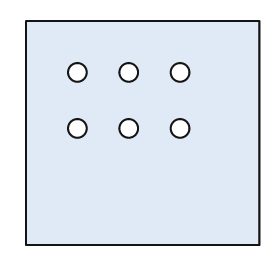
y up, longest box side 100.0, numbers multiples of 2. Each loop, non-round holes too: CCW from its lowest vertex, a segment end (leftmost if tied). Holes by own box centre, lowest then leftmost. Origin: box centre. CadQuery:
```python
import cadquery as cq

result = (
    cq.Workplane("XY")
    .moveTo(-50.0, -48.0)
    .lineTo(50.0, -48.0)
    .lineTo(50.0, 48.0)
    .lineTo(-50.0, 48.0)
    .close()
    .moveTo(-28.0, 2.0)
    .circle(4.0)
    .moveTo(-6.0, 2.0)
    .circle(4.0)
    .moveTo(16.0, 2.0)
    .circle(4.0)
    .moveTo(-28.0, 26.0)
    .circle(4.0)
    .moveTo(-6.0, 26.0)
    .circle(4.0)
    .moveTo(16.0, 26.0)
    .circle(4.0)
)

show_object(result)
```